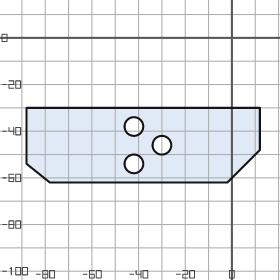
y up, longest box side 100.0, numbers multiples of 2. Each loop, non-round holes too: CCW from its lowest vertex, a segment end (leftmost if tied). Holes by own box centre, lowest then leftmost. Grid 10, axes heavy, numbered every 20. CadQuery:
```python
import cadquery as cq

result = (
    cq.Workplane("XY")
    .moveTo(-78.0, -62.0)
    .lineTo(-2.0, -62.0)
    .lineTo(12.0, -48.0)
    .lineTo(12.0, -30.0)
    .lineTo(-88.0, -30.0)
    .lineTo(-88.0, -54.0)
    .close()
    .moveTo(-42.0, -54.0)
    .circle(4.0)
    .moveTo(-30.0, -46.0)
    .circle(4.0)
    .moveTo(-42.0, -38.0)
    .circle(4.0)
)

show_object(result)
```